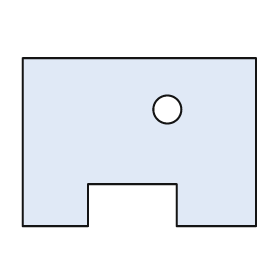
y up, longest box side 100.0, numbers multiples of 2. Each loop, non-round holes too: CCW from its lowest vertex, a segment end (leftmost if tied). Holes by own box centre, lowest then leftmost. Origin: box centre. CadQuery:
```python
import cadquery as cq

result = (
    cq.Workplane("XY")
    .moveTo(-50.0, -36.0)
    .lineTo(-22.0, -36.0)
    .lineTo(-22.0, -18.0)
    .lineTo(16.0, -18.0)
    .lineTo(16.0, -36.0)
    .lineTo(50.0, -36.0)
    .lineTo(50.0, 36.0)
    .lineTo(-50.0, 36.0)
    .close()
    .moveTo(12.0, 14.0)
    .circle(6.0)
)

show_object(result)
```